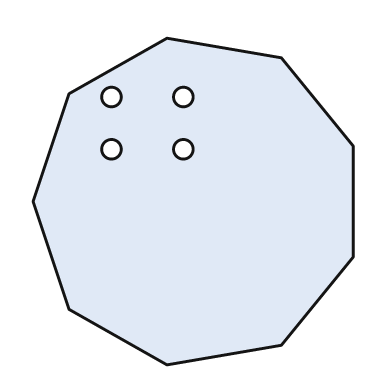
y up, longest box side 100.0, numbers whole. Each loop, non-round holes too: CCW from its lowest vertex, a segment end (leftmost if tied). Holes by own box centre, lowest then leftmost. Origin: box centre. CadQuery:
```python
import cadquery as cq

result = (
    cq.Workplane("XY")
    .moveTo(-8.0, -50.0)
    .lineTo(27.0, -44.0)
    .lineTo(49.0, -17.0)
    .lineTo(49.0, 17.0)
    .lineTo(27.0, 44.0)
    .lineTo(-8.0, 50.0)
    .lineTo(-38.0, 33.0)
    .lineTo(-49.0, 0.0)
    .lineTo(-38.0, -33.0)
    .close()
    .moveTo(-25.0, 16.0)
    .circle(3.0)
    .moveTo(-3.0, 16.0)
    .circle(3.0)
    .moveTo(-25.0, 32.0)
    .circle(3.0)
    .moveTo(-3.0, 32.0)
    .circle(3.0)
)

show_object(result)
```